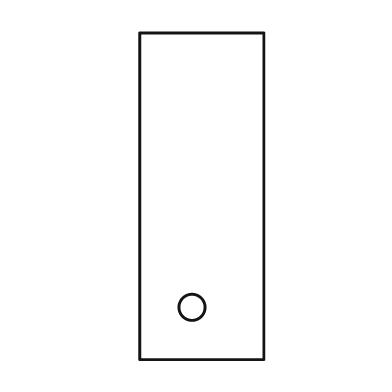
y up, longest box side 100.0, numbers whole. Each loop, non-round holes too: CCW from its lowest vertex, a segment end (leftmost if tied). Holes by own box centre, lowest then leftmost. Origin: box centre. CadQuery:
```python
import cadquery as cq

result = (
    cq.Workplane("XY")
    .moveTo(-19.0, -50.0)
    .lineTo(19.0, -50.0)
    .lineTo(19.0, 50.0)
    .lineTo(-19.0, 50.0)
    .close()
    .moveTo(-3.0, -34.0)
    .circle(4.0)
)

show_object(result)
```